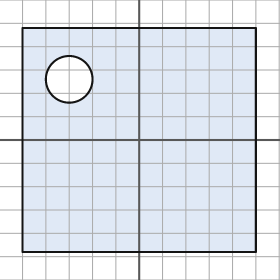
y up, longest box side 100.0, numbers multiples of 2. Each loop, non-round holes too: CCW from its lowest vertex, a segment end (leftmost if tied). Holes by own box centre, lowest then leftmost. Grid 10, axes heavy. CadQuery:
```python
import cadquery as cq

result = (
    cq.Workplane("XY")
    .moveTo(-50.0, -48.0)
    .lineTo(50.0, -48.0)
    .lineTo(50.0, 48.0)
    .lineTo(-50.0, 48.0)
    .close()
    .moveTo(-30.0, 26.0)
    .circle(10.0)
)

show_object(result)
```